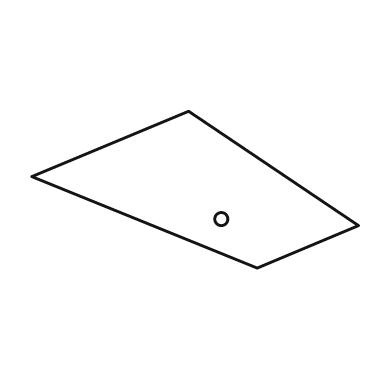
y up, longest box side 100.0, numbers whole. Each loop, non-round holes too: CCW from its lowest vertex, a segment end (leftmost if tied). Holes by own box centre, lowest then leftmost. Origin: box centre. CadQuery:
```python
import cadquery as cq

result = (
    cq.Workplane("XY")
    .moveTo(19.0, -24.0)
    .lineTo(50.0, -11.0)
    .lineTo(-2.0, 24.0)
    .lineTo(-50.0, 4.0)
    .close()
    .moveTo(8.0, -9.0)
    .circle(2.0)
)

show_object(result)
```